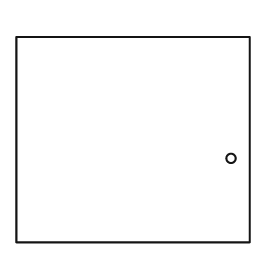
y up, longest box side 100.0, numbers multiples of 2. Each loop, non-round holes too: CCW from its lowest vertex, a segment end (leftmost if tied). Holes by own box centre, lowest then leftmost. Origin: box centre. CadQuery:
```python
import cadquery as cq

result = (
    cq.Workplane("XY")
    .moveTo(-50.0, -44.0)
    .lineTo(50.0, -44.0)
    .lineTo(50.0, 44.0)
    .lineTo(-50.0, 44.0)
    .close()
    .moveTo(42.0, -8.0)
    .circle(2.0)
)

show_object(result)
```